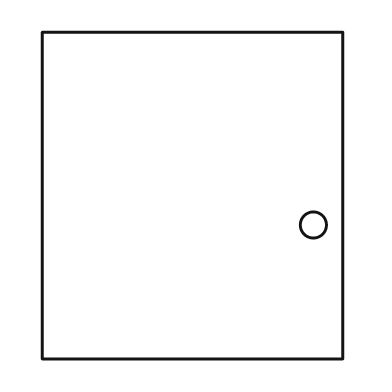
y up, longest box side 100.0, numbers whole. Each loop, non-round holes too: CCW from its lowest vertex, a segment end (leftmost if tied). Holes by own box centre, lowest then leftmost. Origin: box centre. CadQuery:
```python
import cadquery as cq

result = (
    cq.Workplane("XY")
    .moveTo(-46.0, -50.0)
    .lineTo(46.0, -50.0)
    .lineTo(46.0, 50.0)
    .lineTo(-46.0, 50.0)
    .close()
    .moveTo(37.0, -9.0)
    .circle(4.0)
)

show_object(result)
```